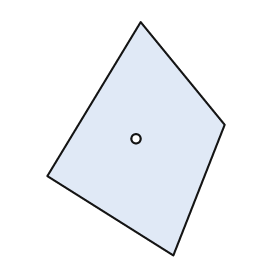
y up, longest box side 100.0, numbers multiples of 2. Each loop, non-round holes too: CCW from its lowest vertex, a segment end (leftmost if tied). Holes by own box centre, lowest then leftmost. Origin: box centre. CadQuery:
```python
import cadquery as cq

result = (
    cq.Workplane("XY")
    .moveTo(16.0, -50.0)
    .lineTo(38.0, 6.0)
    .lineTo(2.0, 50.0)
    .lineTo(-38.0, -16.0)
    .close()
    .moveTo(0.0, 0.0)
    .circle(2.0)
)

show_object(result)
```